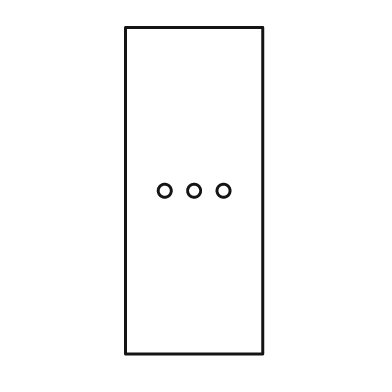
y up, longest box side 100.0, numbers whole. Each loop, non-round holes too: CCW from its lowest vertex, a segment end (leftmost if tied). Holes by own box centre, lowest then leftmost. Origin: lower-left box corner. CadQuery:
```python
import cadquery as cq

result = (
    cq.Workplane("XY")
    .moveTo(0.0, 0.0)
    .lineTo(42.0, 0.0)
    .lineTo(42.0, 100.0)
    .lineTo(0.0, 100.0)
    .close()
    .moveTo(12.0, 50.0)
    .circle(2.0)
    .moveTo(21.0, 50.0)
    .circle(2.0)
    .moveTo(30.0, 50.0)
    .circle(2.0)
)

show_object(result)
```